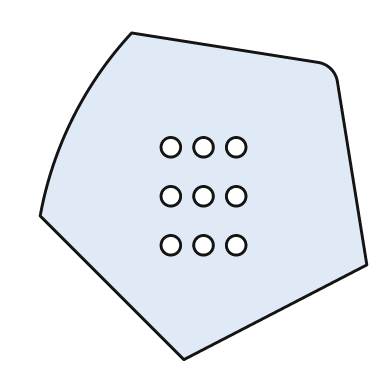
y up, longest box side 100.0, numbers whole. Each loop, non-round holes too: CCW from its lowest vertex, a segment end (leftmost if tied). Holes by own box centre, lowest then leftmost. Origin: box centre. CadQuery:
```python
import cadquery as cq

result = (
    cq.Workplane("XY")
    .moveTo(-6.0, -50.0)
    .lineTo(50.0, -21.0)
    .lineTo(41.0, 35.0)
    .threePointArc((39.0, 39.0), (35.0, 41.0))
    .lineTo(-22.0, 50.0)
    .threePointArc((-40.0, 24.0), (-50.0, -6.0))
    .close()
    .moveTo(-10.0, -15.0)
    .circle(3.0)
    .moveTo(0.0, -15.0)
    .circle(3.0)
    .moveTo(10.0, -15.0)
    .circle(3.0)
    .moveTo(-10.0, 0.0)
    .circle(3.0)
    .moveTo(0.0, 0.0)
    .circle(3.0)
    .moveTo(10.0, 0.0)
    .circle(3.0)
    .moveTo(-10.0, 15.0)
    .circle(3.0)
    .moveTo(0.0, 15.0)
    .circle(3.0)
    .moveTo(10.0, 15.0)
    .circle(3.0)
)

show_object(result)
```